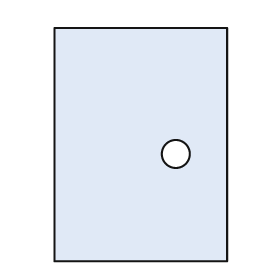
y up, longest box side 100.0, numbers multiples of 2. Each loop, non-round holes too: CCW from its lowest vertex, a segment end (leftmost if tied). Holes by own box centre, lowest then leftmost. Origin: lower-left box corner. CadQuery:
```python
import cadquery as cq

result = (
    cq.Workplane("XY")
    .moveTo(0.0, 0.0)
    .lineTo(74.0, 0.0)
    .lineTo(74.0, 100.0)
    .lineTo(0.0, 100.0)
    .close()
    .moveTo(52.0, 46.0)
    .circle(6.0)
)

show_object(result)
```